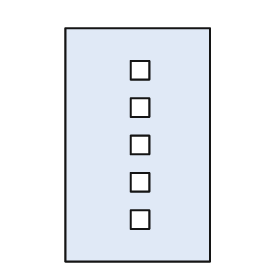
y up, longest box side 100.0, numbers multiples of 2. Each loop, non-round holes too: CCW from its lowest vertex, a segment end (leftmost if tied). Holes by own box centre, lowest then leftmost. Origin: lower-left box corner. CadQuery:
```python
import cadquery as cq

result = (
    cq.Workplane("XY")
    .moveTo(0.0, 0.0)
    .lineTo(62.0, 0.0)
    .lineTo(62.0, 100.0)
    .lineTo(0.0, 100.0)
    .close()
    .moveTo(28.0, 14.0)
    .lineTo(36.0, 14.0)
    .lineTo(36.0, 22.0)
    .lineTo(28.0, 22.0)
    .close()
    .moveTo(28.0, 30.0)
    .lineTo(36.0, 30.0)
    .lineTo(36.0, 38.0)
    .lineTo(28.0, 38.0)
    .close()
    .moveTo(28.0, 46.0)
    .lineTo(36.0, 46.0)
    .lineTo(36.0, 54.0)
    .lineTo(28.0, 54.0)
    .close()
    .moveTo(28.0, 62.0)
    .lineTo(36.0, 62.0)
    .lineTo(36.0, 70.0)
    .lineTo(28.0, 70.0)
    .close()
    .moveTo(28.0, 78.0)
    .lineTo(36.0, 78.0)
    .lineTo(36.0, 86.0)
    .lineTo(28.0, 86.0)
    .close()
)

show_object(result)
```